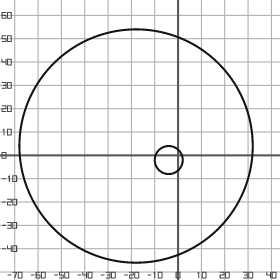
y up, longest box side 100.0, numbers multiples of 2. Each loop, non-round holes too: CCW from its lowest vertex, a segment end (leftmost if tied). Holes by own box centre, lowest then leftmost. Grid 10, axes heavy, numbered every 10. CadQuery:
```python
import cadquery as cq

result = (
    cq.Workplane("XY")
    .moveTo(-18.0, 4.0)
    .circle(50.0)
    .moveTo(-4.0, -2.0)
    .circle(6.0)
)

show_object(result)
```